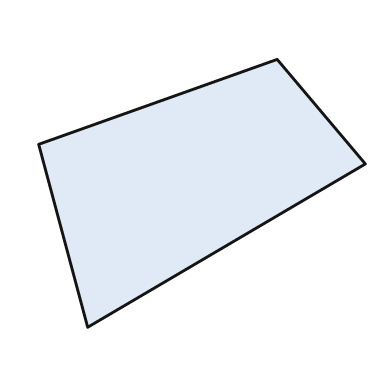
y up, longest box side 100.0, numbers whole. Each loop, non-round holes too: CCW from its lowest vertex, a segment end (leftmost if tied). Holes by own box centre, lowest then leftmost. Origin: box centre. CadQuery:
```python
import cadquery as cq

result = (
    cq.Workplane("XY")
    .moveTo(-35.0, -41.0)
    .lineTo(50.0, 9.0)
    .lineTo(23.0, 41.0)
    .lineTo(-50.0, 15.0)
    .close()
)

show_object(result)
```